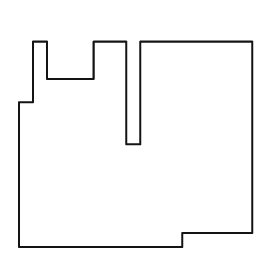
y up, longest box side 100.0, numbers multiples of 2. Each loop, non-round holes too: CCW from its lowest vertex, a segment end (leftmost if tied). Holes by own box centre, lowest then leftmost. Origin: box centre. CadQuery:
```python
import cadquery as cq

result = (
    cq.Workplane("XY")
    .moveTo(-50.0, -44.0)
    .lineTo(20.0, -44.0)
    .lineTo(20.0, -38.0)
    .lineTo(50.0, -38.0)
    .lineTo(50.0, 44.0)
    .lineTo(2.0, 44.0)
    .lineTo(2.0, 0.0)
    .lineTo(-4.0, 0.0)
    .lineTo(-4.0, 44.0)
    .lineTo(-18.0, 44.0)
    .lineTo(-18.0, 28.0)
    .lineTo(-38.0, 28.0)
    .lineTo(-38.0, 44.0)
    .lineTo(-44.0, 44.0)
    .lineTo(-44.0, 18.0)
    .lineTo(-50.0, 18.0)
    .close()
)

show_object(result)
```